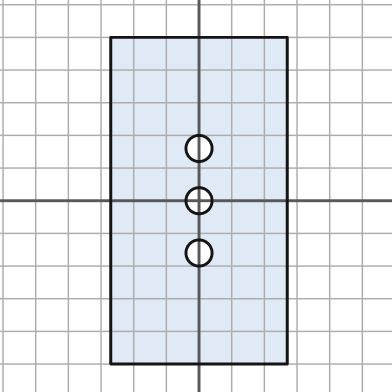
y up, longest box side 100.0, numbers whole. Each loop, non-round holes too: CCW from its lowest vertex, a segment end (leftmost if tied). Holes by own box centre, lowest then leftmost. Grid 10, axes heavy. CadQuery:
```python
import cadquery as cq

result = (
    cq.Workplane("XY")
    .moveTo(-27.0, -50.0)
    .lineTo(27.0, -50.0)
    .lineTo(27.0, 50.0)
    .lineTo(-27.0, 50.0)
    .close()
    .moveTo(0.0, -16.0)
    .circle(4.0)
    .moveTo(0.0, 0.0)
    .circle(4.0)
    .moveTo(0.0, 16.0)
    .circle(4.0)
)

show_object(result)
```